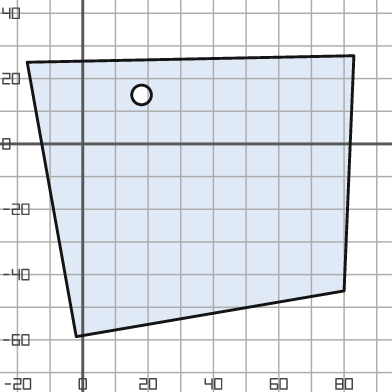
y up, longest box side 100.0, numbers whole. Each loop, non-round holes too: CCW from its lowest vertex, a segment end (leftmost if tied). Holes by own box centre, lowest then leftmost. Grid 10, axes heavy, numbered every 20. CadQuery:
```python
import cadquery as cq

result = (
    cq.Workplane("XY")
    .moveTo(-2.0, -59.0)
    .lineTo(80.0, -45.0)
    .lineTo(83.0, 27.0)
    .lineTo(-17.0, 25.0)
    .close()
    .moveTo(18.0, 15.0)
    .circle(3.0)
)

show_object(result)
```